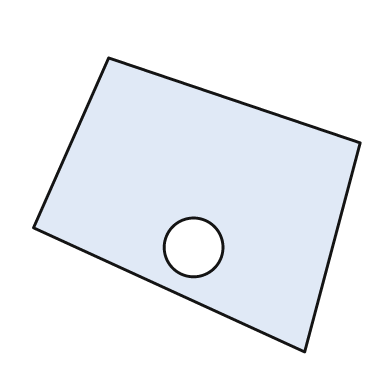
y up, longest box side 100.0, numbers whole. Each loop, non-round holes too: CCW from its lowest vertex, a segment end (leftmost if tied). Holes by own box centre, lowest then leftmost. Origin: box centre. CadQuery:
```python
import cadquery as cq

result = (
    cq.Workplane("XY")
    .moveTo(33.0, -45.0)
    .lineTo(50.0, 19.0)
    .lineTo(-27.0, 45.0)
    .lineTo(-50.0, -7.0)
    .close()
    .moveTo(-1.0, -13.0)
    .circle(9.0)
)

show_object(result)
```